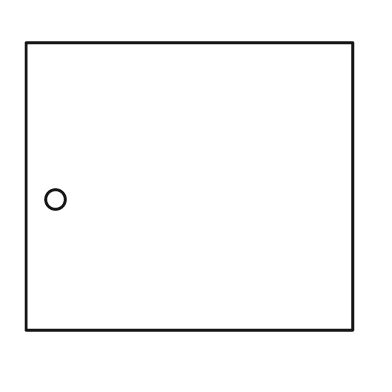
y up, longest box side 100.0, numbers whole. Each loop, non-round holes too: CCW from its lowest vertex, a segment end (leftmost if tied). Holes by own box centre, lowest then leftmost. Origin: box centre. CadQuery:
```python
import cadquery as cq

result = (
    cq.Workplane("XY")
    .moveTo(-50.0, -44.0)
    .lineTo(50.0, -44.0)
    .lineTo(50.0, 44.0)
    .lineTo(-50.0, 44.0)
    .close()
    .moveTo(-41.0, -4.0)
    .circle(3.0)
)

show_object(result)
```